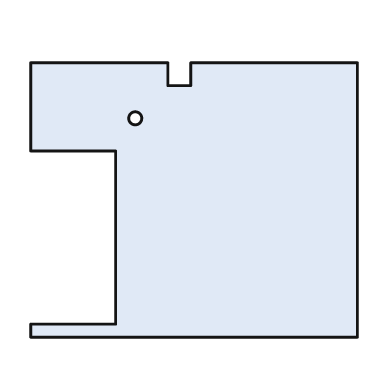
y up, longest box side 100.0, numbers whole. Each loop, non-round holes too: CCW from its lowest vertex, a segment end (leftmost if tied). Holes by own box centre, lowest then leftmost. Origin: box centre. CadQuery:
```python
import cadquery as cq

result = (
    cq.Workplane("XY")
    .moveTo(-50.0, -42.0)
    .lineTo(50.0, -42.0)
    .lineTo(50.0, 42.0)
    .lineTo(-1.0, 42.0)
    .lineTo(-1.0, 35.0)
    .lineTo(-8.0, 35.0)
    .lineTo(-8.0, 42.0)
    .lineTo(-50.0, 42.0)
    .lineTo(-50.0, 15.0)
    .lineTo(-24.0, 15.0)
    .lineTo(-24.0, -38.0)
    .lineTo(-50.0, -38.0)
    .close()
    .moveTo(-18.0, 25.0)
    .circle(2.0)
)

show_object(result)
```